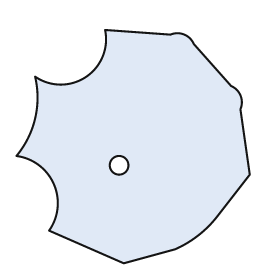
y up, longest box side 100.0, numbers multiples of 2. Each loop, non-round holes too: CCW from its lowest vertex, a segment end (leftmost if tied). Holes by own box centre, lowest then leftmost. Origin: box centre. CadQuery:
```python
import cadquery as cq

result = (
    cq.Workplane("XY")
    .moveTo(-4.0, -50.0)
    .lineTo(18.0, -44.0)
    .threePointArc((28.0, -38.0), (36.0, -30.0))
    .lineTo(50.0, -12.0)
    .lineTo(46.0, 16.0)
    .threePointArc((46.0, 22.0), (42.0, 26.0))
    .lineTo(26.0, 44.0)
    .threePointArc((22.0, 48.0), (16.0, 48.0))
    .lineTo(-12.0, 50.0)
    .threePointArc((-20.0, 30.0), (-42.0, 30.0))
    .threePointArc((-42.0, 12.0), (-50.0, -4.0))
    .threePointArc((-34.0, -16.0), (-36.0, -36.0))
    .close()
    .moveTo(-6.0, -8.0)
    .circle(4.0)
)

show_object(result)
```